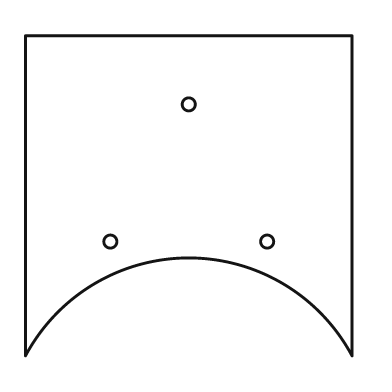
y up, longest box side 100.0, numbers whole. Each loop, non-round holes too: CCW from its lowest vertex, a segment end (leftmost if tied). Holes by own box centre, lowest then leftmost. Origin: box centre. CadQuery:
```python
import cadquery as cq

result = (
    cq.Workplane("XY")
    .moveTo(-50.0, -49.0)
    .threePointArc((0.0, -19.0), (50.0, -49.0))
    .lineTo(50.0, 49.0)
    .lineTo(-50.0, 49.0)
    .close()
    .moveTo(-24.0, -14.0)
    .circle(2.0)
    .moveTo(24.0, -14.0)
    .circle(2.0)
    .moveTo(0.0, 28.0)
    .circle(2.0)
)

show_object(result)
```